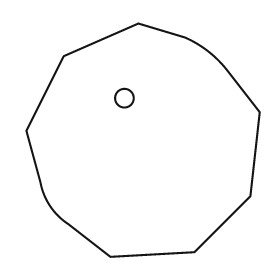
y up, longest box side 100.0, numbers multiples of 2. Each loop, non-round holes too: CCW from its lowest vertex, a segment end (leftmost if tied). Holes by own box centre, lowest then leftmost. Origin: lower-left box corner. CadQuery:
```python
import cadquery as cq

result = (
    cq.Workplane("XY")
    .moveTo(36.0, 0.0)
    .lineTo(72.0, 2.0)
    .lineTo(96.0, 26.0)
    .lineTo(100.0, 62.0)
    .lineTo(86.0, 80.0)
    .threePointArc((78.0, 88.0), (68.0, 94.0))
    .lineTo(48.0, 100.0)
    .lineTo(16.0, 86.0)
    .lineTo(0.0, 54.0)
    .lineTo(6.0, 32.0)
    .threePointArc((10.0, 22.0), (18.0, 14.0))
    .close()
    .moveTo(42.0, 68.0)
    .circle(4.0)
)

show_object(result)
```